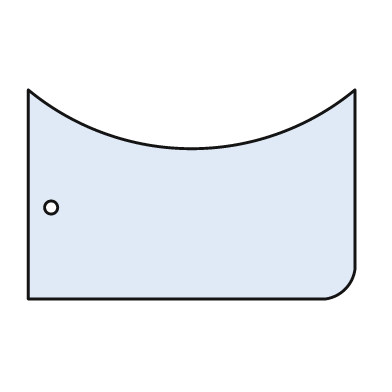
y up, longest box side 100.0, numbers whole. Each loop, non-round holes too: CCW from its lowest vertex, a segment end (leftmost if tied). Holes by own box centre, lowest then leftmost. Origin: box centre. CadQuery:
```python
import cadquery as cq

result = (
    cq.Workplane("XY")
    .moveTo(-50.0, -32.0)
    .lineTo(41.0, -32.0)
    .threePointArc((47.0, -29.0), (50.0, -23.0))
    .lineTo(50.0, 32.0)
    .threePointArc((0.0, 14.0), (-50.0, 32.0))
    .close()
    .moveTo(-43.0, -4.0)
    .circle(2.0)
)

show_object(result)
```